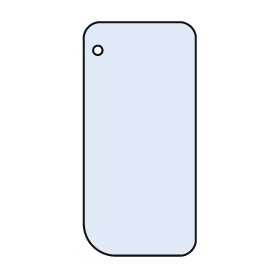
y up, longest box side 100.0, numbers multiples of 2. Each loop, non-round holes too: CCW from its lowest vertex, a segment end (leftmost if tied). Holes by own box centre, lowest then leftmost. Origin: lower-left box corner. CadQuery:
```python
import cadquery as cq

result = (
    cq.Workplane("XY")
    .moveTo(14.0, 0.0)
    .lineTo(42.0, 0.0)
    .threePointArc((46.0, 2.0), (48.0, 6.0))
    .lineTo(48.0, 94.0)
    .threePointArc((46.0, 98.0), (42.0, 100.0))
    .lineTo(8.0, 100.0)
    .threePointArc((2.0, 98.0), (0.0, 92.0))
    .lineTo(0.0, 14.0)
    .threePointArc((4.0, 4.0), (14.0, 0.0))
    .close()
    .moveTo(6.0, 88.0)
    .circle(2.0)
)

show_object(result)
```